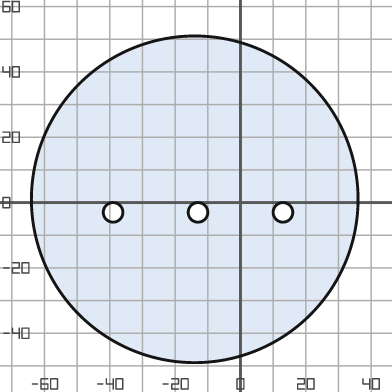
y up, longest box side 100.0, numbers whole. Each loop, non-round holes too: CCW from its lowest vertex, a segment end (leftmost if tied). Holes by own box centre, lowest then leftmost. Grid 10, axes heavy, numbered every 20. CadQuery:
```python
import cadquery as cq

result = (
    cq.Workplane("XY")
    .moveTo(-14.0, 1.0)
    .circle(50.0)
    .moveTo(-39.0, -3.0)
    .circle(3.0)
    .moveTo(-13.0, -3.0)
    .circle(3.0)
    .moveTo(13.0, -3.0)
    .circle(3.0)
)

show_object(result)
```